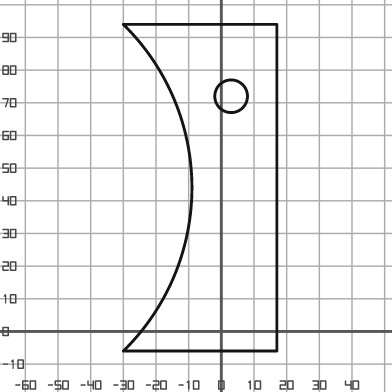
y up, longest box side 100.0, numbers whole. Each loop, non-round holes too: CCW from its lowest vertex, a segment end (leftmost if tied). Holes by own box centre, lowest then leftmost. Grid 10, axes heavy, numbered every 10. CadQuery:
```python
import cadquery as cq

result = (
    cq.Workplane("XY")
    .moveTo(-30.0, -6.0)
    .lineTo(17.0, -6.0)
    .lineTo(17.0, 94.0)
    .lineTo(-30.0, 94.0)
    .threePointArc((-9.0, 44.0), (-30.0, -6.0))
    .close()
    .moveTo(3.0, 72.0)
    .circle(5.0)
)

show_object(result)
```